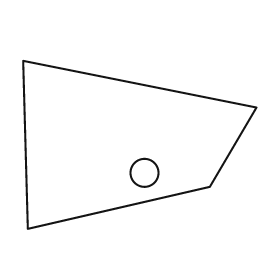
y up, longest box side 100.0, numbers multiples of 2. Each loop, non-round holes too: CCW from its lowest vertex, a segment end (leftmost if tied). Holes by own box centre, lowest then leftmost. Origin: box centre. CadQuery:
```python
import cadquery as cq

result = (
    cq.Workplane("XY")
    .moveTo(-48.0, -36.0)
    .lineTo(30.0, -18.0)
    .lineTo(50.0, 16.0)
    .lineTo(-50.0, 36.0)
    .close()
    .moveTo(2.0, -12.0)
    .circle(6.0)
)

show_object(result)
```